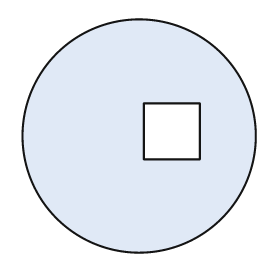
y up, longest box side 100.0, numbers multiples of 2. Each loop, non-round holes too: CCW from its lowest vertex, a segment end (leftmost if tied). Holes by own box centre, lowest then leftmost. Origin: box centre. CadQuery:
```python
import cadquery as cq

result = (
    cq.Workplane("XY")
    .moveTo(0.0, 0.0)
    .circle(50.0)
    .moveTo(2.0, -10.0)
    .lineTo(26.0, -10.0)
    .lineTo(26.0, 14.0)
    .lineTo(2.0, 14.0)
    .close()
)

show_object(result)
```